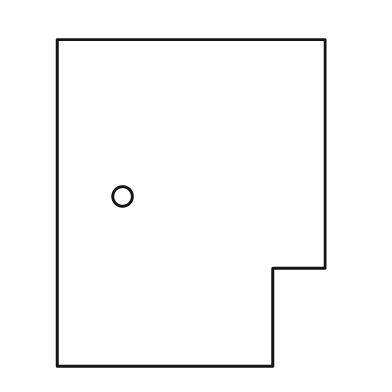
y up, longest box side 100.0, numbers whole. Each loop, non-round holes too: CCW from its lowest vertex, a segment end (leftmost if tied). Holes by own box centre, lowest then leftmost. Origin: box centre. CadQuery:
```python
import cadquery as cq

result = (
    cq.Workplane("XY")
    .moveTo(-41.0, -50.0)
    .lineTo(25.0, -50.0)
    .lineTo(25.0, -20.0)
    .lineTo(41.0, -20.0)
    .lineTo(41.0, 50.0)
    .lineTo(-41.0, 50.0)
    .close()
    .moveTo(-21.0, 2.0)
    .circle(3.0)
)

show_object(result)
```